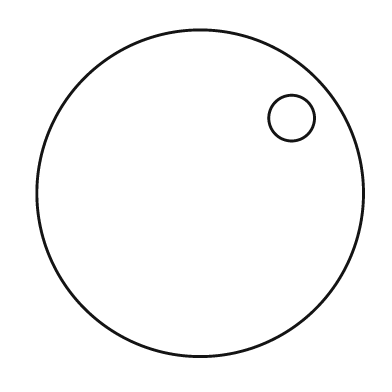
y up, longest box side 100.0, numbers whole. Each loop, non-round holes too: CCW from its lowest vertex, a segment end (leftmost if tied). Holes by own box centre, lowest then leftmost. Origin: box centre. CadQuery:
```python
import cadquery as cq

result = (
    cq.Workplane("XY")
    .moveTo(0.0, 0.0)
    .circle(50.0)
    .moveTo(28.0, 23.0)
    .circle(7.0)
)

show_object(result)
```